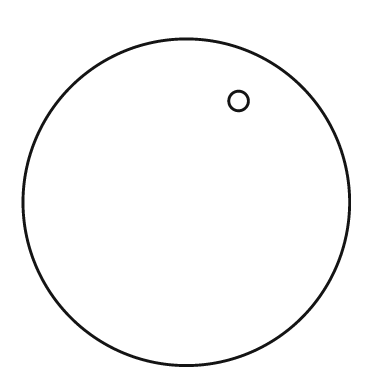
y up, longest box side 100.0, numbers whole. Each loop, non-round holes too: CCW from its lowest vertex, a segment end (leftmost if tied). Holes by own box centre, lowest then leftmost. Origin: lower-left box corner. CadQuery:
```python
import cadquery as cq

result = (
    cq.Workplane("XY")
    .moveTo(50.0, 50.0)
    .circle(50.0)
    .moveTo(66.0, 81.0)
    .circle(3.0)
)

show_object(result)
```